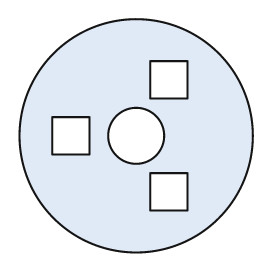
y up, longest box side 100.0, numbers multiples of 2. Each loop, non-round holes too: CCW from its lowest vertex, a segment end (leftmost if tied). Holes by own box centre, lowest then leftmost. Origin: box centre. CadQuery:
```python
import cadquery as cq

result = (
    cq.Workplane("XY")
    .moveTo(0.0, 0.0)
    .circle(50.0)
    .moveTo(6.0, -32.0)
    .lineTo(22.0, -32.0)
    .lineTo(22.0, -16.0)
    .lineTo(6.0, -16.0)
    .close()
    .moveTo(-36.0, -8.0)
    .lineTo(-20.0, -8.0)
    .lineTo(-20.0, 8.0)
    .lineTo(-36.0, 8.0)
    .close()
    .moveTo(0.0, 0.0)
    .circle(12.0)
    .moveTo(6.0, 16.0)
    .lineTo(22.0, 16.0)
    .lineTo(22.0, 32.0)
    .lineTo(6.0, 32.0)
    .close()
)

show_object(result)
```